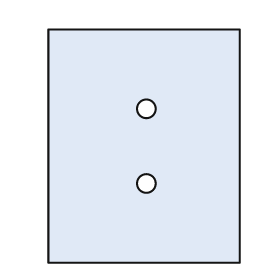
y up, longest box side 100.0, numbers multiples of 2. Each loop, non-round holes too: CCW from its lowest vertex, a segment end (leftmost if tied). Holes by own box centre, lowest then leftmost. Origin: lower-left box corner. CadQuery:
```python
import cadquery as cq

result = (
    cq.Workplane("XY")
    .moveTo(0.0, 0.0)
    .lineTo(82.0, 0.0)
    .lineTo(82.0, 100.0)
    .lineTo(0.0, 100.0)
    .close()
    .moveTo(42.0, 34.0)
    .circle(4.0)
    .moveTo(42.0, 66.0)
    .circle(4.0)
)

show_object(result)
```